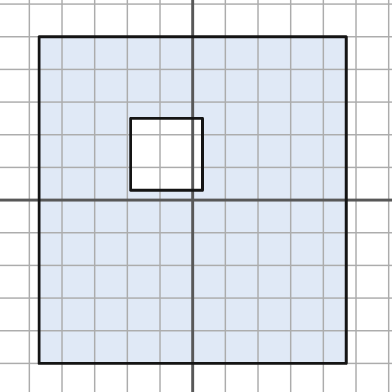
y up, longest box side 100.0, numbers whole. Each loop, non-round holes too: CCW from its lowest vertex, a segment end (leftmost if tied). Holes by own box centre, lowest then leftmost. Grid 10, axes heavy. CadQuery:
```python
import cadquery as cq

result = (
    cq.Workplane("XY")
    .moveTo(-47.0, -50.0)
    .lineTo(47.0, -50.0)
    .lineTo(47.0, 50.0)
    .lineTo(-47.0, 50.0)
    .close()
    .moveTo(-19.0, 3.0)
    .lineTo(3.0, 3.0)
    .lineTo(3.0, 25.0)
    .lineTo(-19.0, 25.0)
    .close()
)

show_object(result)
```